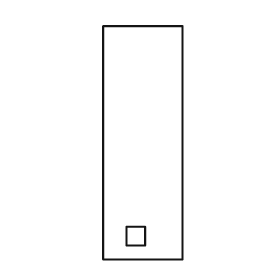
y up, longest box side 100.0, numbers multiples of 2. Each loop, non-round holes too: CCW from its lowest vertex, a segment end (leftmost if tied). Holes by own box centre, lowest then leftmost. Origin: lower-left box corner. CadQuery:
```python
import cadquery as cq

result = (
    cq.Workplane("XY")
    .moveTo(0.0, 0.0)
    .lineTo(34.0, 0.0)
    .lineTo(34.0, 100.0)
    .lineTo(0.0, 100.0)
    .close()
    .moveTo(10.0, 6.0)
    .lineTo(18.0, 6.0)
    .lineTo(18.0, 14.0)
    .lineTo(10.0, 14.0)
    .close()
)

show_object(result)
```